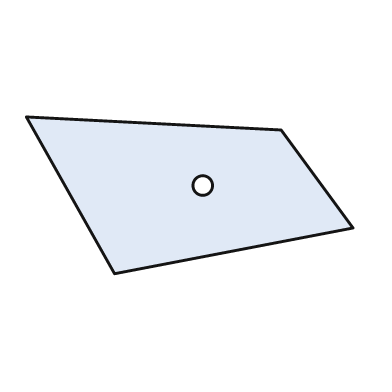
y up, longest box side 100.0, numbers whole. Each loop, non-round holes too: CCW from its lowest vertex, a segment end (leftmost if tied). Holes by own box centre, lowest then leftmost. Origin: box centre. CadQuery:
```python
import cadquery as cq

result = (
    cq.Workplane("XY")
    .moveTo(-23.0, -24.0)
    .lineTo(50.0, -10.0)
    .lineTo(28.0, 20.0)
    .lineTo(-50.0, 24.0)
    .close()
    .moveTo(4.0, 3.0)
    .circle(3.0)
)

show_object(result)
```